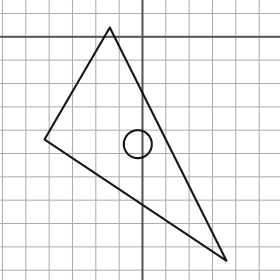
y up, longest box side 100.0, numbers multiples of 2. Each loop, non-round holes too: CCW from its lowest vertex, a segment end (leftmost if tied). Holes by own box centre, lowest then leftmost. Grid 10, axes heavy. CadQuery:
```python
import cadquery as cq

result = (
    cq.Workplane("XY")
    .moveTo(36.0, -96.0)
    .lineTo(-14.0, 4.0)
    .lineTo(-42.0, -44.0)
    .close()
    .moveTo(-2.0, -46.0)
    .circle(6.0)
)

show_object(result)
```